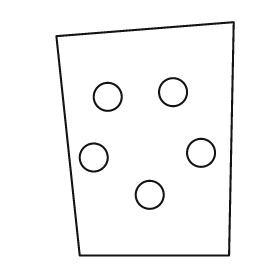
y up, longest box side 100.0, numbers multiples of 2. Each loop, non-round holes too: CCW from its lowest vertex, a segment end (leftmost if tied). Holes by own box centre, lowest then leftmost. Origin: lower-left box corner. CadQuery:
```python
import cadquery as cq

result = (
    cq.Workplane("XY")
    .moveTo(10.0, 0.0)
    .lineTo(74.0, 0.0)
    .lineTo(76.0, 100.0)
    .lineTo(0.0, 94.0)
    .close()
    .moveTo(40.0, 26.0)
    .circle(6.0)
    .moveTo(16.0, 42.0)
    .circle(6.0)
    .moveTo(62.0, 44.0)
    .circle(6.0)
    .moveTo(22.0, 68.0)
    .circle(6.0)
    .moveTo(50.0, 70.0)
    .circle(6.0)
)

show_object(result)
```